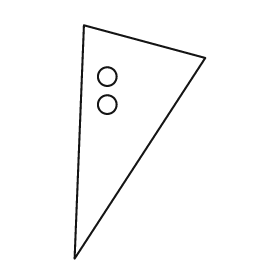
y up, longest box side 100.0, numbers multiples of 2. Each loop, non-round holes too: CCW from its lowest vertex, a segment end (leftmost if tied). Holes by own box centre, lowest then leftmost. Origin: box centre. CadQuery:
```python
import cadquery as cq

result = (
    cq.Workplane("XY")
    .moveTo(-28.0, -50.0)
    .lineTo(28.0, 36.0)
    .lineTo(-24.0, 50.0)
    .close()
    .moveTo(-14.0, 16.0)
    .circle(4.0)
    .moveTo(-14.0, 28.0)
    .circle(4.0)
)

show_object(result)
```